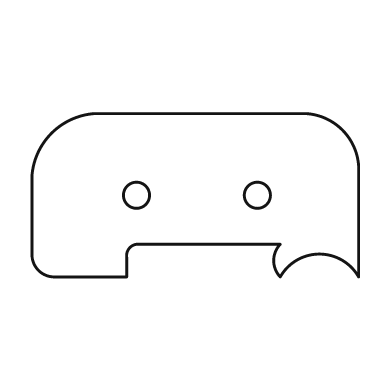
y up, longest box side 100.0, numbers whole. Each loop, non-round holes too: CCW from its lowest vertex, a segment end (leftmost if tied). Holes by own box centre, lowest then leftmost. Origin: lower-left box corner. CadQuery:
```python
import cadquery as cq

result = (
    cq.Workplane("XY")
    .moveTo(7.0, 0.0)
    .lineTo(29.0, 0.0)
    .lineTo(29.0, 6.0)
    .threePointArc((30.0, 9.0), (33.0, 10.0))
    .lineTo(76.0, 10.0)
    .threePointArc((74.0, 5.0), (76.0, 0.0))
    .threePointArc((88.0, 7.0), (100.0, 0.0))
    .lineTo(100.0, 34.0)
    .threePointArc((95.0, 45.0), (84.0, 50.0))
    .lineTo(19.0, 50.0)
    .threePointArc((6.0, 44.0), (0.0, 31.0))
    .lineTo(0.0, 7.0)
    .threePointArc((2.0, 2.0), (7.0, 0.0))
    .close()
    .moveTo(32.0, 25.0)
    .circle(4.0)
    .moveTo(69.0, 25.0)
    .circle(4.0)
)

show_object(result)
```